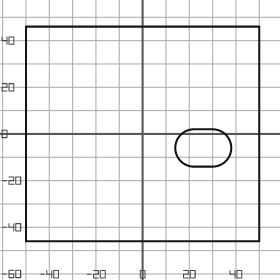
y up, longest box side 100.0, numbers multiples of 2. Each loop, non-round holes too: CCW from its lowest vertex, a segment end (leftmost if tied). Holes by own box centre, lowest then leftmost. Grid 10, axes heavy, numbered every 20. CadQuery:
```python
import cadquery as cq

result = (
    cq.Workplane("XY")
    .moveTo(-50.0, -46.0)
    .lineTo(50.0, -46.0)
    .lineTo(50.0, 46.0)
    .lineTo(-50.0, 46.0)
    .close()
    .moveTo(22.0, -14.0)
    .lineTo(30.0, -14.0)
    .threePointArc((38.0, -6.0), (30.0, 2.0))
    .lineTo(22.0, 2.0)
    .threePointArc((14.0, -6.0), (22.0, -14.0))
    .close()
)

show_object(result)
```